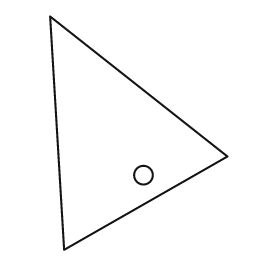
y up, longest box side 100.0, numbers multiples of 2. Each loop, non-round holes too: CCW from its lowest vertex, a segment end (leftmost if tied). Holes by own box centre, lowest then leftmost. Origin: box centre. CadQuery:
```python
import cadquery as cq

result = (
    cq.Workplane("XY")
    .moveTo(-32.0, -50.0)
    .lineTo(38.0, -10.0)
    .lineTo(-38.0, 50.0)
    .close()
    .moveTo(2.0, -18.0)
    .circle(4.0)
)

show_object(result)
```